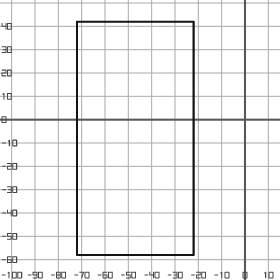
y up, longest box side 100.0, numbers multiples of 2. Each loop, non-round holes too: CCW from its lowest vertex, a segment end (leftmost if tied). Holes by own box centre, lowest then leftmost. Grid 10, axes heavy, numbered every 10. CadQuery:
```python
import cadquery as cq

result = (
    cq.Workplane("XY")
    .moveTo(-72.0, -58.0)
    .lineTo(-22.0, -58.0)
    .lineTo(-22.0, 42.0)
    .lineTo(-72.0, 42.0)
    .close()
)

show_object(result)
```